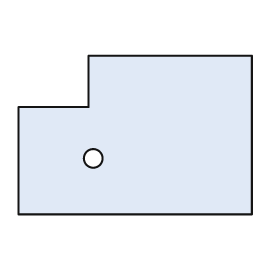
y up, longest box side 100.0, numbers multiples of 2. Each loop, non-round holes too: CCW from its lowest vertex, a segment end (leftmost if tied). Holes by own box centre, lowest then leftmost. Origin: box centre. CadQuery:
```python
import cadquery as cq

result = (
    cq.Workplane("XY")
    .moveTo(-50.0, -34.0)
    .lineTo(50.0, -34.0)
    .lineTo(50.0, 34.0)
    .lineTo(-20.0, 34.0)
    .lineTo(-20.0, 12.0)
    .lineTo(-50.0, 12.0)
    .close()
    .moveTo(-18.0, -10.0)
    .circle(4.0)
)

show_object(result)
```